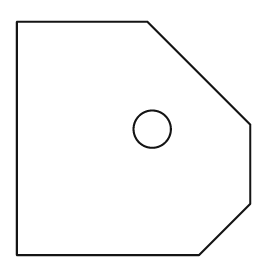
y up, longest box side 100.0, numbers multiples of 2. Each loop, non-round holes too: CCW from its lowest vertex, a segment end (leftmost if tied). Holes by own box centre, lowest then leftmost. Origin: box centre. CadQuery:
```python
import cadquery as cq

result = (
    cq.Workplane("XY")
    .moveTo(-50.0, -50.0)
    .lineTo(28.0, -50.0)
    .lineTo(50.0, -28.0)
    .lineTo(50.0, 6.0)
    .lineTo(6.0, 50.0)
    .lineTo(-50.0, 50.0)
    .close()
    .moveTo(8.0, 4.0)
    .circle(8.0)
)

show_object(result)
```